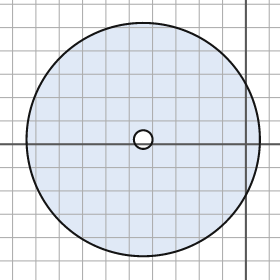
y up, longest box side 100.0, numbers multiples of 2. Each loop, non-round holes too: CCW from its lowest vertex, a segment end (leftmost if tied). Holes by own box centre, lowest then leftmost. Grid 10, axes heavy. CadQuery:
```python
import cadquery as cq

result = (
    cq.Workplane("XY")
    .moveTo(-44.0, 2.0)
    .circle(50.0)
    .moveTo(-44.0, 2.0)
    .circle(4.0)
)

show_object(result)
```